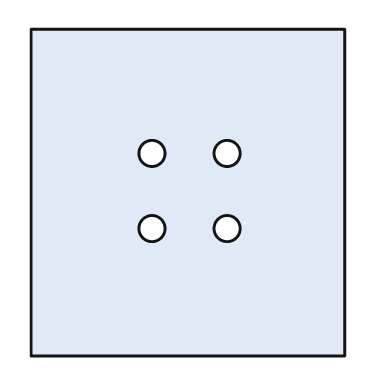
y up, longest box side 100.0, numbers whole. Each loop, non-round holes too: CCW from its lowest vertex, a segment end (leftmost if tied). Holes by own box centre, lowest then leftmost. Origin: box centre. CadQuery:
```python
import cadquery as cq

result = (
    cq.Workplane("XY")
    .moveTo(-48.0, -50.0)
    .lineTo(48.0, -50.0)
    .lineTo(48.0, 50.0)
    .lineTo(-48.0, 50.0)
    .close()
    .moveTo(-11.0, -11.0)
    .circle(4.0)
    .moveTo(12.0, -11.0)
    .circle(4.0)
    .moveTo(-11.0, 12.0)
    .circle(4.0)
    .moveTo(12.0, 12.0)
    .circle(4.0)
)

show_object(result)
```